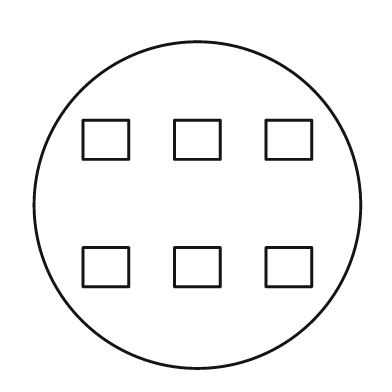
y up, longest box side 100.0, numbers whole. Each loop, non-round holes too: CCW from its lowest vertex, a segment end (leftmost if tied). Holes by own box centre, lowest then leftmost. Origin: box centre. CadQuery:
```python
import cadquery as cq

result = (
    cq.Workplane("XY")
    .moveTo(0.0, 0.0)
    .circle(50.0)
    .moveTo(-35.0, -25.0)
    .lineTo(-21.0, -25.0)
    .lineTo(-21.0, -13.0)
    .lineTo(-35.0, -13.0)
    .close()
    .moveTo(-7.0, -25.0)
    .lineTo(7.0, -25.0)
    .lineTo(7.0, -13.0)
    .lineTo(-7.0, -13.0)
    .close()
    .moveTo(21.0, -25.0)
    .lineTo(35.0, -25.0)
    .lineTo(35.0, -13.0)
    .lineTo(21.0, -13.0)
    .close()
    .moveTo(-35.0, 14.0)
    .lineTo(-21.0, 14.0)
    .lineTo(-21.0, 26.0)
    .lineTo(-35.0, 26.0)
    .close()
    .moveTo(-7.0, 14.0)
    .lineTo(7.0, 14.0)
    .lineTo(7.0, 26.0)
    .lineTo(-7.0, 26.0)
    .close()
    .moveTo(21.0, 14.0)
    .lineTo(35.0, 14.0)
    .lineTo(35.0, 26.0)
    .lineTo(21.0, 26.0)
    .close()
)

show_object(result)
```